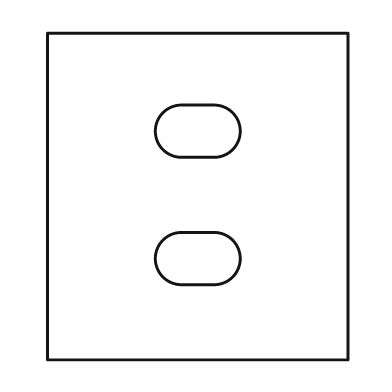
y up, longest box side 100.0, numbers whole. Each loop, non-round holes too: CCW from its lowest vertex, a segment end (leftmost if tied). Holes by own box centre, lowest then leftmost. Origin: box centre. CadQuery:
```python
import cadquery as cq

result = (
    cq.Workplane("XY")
    .moveTo(-46.0, -50.0)
    .lineTo(46.0, -50.0)
    .lineTo(46.0, 50.0)
    .lineTo(-46.0, 50.0)
    .close()
    .moveTo(-5.0, -27.0)
    .lineTo(5.0, -27.0)
    .threePointArc((13.0, -19.0), (5.0, -11.0))
    .lineTo(-5.0, -11.0)
    .threePointArc((-13.0, -19.0), (-5.0, -27.0))
    .close()
    .moveTo(-5.0, 12.0)
    .lineTo(5.0, 12.0)
    .threePointArc((13.0, 20.0), (5.0, 28.0))
    .lineTo(-5.0, 28.0)
    .threePointArc((-13.0, 20.0), (-5.0, 12.0))
    .close()
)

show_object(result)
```